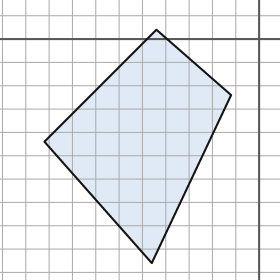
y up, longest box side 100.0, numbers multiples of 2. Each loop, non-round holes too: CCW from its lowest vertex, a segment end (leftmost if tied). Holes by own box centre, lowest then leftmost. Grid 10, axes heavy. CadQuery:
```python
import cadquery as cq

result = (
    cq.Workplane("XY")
    .moveTo(-46.0, -96.0)
    .lineTo(-12.0, -24.0)
    .lineTo(-44.0, 4.0)
    .lineTo(-92.0, -44.0)
    .close()
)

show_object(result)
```